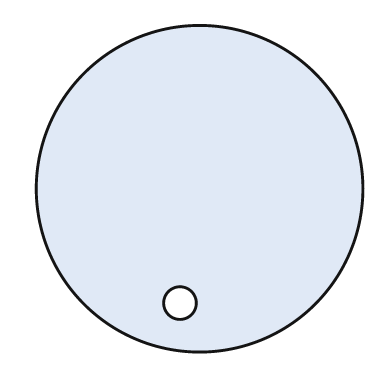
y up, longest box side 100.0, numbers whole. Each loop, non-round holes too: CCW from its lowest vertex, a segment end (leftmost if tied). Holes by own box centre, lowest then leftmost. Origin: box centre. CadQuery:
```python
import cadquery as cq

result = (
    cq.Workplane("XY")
    .moveTo(0.0, 0.0)
    .circle(50.0)
    .moveTo(-6.0, -35.0)
    .circle(5.0)
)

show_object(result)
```